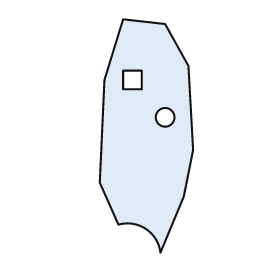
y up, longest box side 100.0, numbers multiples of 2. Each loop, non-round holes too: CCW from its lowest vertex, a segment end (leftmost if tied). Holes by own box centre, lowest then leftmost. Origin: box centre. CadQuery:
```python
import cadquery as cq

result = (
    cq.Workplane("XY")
    .moveTo(6.0, -50.0)
    .lineTo(16.0, -26.0)
    .lineTo(20.0, -6.0)
    .lineTo(18.0, 30.0)
    .lineTo(8.0, 48.0)
    .lineTo(-10.0, 50.0)
    .lineTo(-18.0, 24.0)
    .lineTo(-20.0, -20.0)
    .lineTo(-12.0, -38.0)
    .threePointArc((0.0, -40.0), (6.0, -50.0))
    .close()
    .moveTo(8.0, 8.0)
    .circle(4.0)
    .moveTo(-10.0, 20.0)
    .lineTo(-2.0, 20.0)
    .lineTo(-2.0, 28.0)
    .lineTo(-10.0, 28.0)
    .close()
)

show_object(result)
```